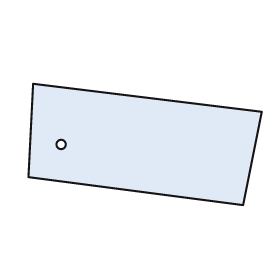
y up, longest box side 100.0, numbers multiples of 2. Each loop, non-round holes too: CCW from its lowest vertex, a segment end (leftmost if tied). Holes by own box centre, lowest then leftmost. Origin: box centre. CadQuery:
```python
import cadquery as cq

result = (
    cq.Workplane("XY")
    .moveTo(42.0, -26.0)
    .lineTo(50.0, 14.0)
    .lineTo(-48.0, 26.0)
    .lineTo(-50.0, -14.0)
    .close()
    .moveTo(-36.0, 0.0)
    .circle(2.0)
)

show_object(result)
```